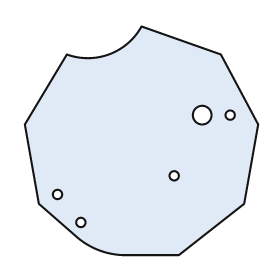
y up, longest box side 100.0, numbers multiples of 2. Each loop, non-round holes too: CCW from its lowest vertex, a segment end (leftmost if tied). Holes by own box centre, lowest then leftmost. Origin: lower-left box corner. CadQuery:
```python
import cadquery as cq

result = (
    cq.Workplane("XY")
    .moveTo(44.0, 0.0)
    .lineTo(66.0, 0.0)
    .lineTo(94.0, 22.0)
    .lineTo(100.0, 56.0)
    .lineTo(84.0, 86.0)
    .lineTo(50.0, 98.0)
    .threePointArc((36.0, 86.0), (18.0, 86.0))
    .lineTo(0.0, 56.0)
    .lineTo(6.0, 22.0)
    .lineTo(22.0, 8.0)
    .threePointArc((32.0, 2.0), (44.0, 0.0))
    .close()
    .moveTo(24.0, 14.0)
    .circle(2.0)
    .moveTo(14.0, 26.0)
    .circle(2.0)
    .moveTo(64.0, 34.0)
    .circle(2.0)
    .moveTo(76.0, 60.0)
    .circle(4.0)
    .moveTo(88.0, 60.0)
    .circle(2.0)
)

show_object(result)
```